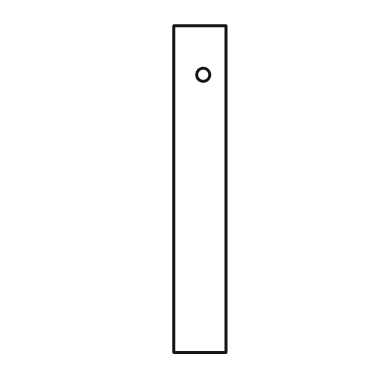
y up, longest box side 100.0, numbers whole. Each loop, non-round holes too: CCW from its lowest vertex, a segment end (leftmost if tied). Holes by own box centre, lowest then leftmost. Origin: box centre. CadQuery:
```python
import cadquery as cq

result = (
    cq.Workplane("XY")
    .moveTo(-8.0, -50.0)
    .lineTo(8.0, -50.0)
    .lineTo(8.0, 50.0)
    .lineTo(-8.0, 50.0)
    .close()
    .moveTo(1.0, 35.0)
    .circle(2.0)
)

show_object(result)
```